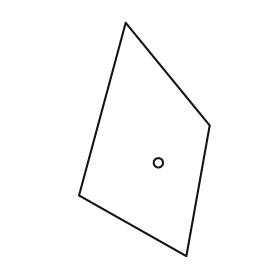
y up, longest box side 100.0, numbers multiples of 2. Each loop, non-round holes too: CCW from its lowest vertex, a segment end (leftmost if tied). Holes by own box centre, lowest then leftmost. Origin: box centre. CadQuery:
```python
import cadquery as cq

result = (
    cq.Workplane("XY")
    .moveTo(18.0, -50.0)
    .lineTo(28.0, 6.0)
    .lineTo(-8.0, 50.0)
    .lineTo(-28.0, -24.0)
    .close()
    .moveTo(6.0, -10.0)
    .circle(2.0)
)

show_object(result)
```